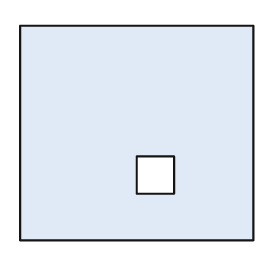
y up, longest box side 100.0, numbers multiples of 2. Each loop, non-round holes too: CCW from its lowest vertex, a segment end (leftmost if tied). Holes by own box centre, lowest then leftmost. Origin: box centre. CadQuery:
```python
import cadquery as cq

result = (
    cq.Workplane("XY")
    .moveTo(-50.0, -46.0)
    .lineTo(50.0, -46.0)
    .lineTo(50.0, 46.0)
    .lineTo(-50.0, 46.0)
    .close()
    .moveTo(0.0, -26.0)
    .lineTo(16.0, -26.0)
    .lineTo(16.0, -10.0)
    .lineTo(0.0, -10.0)
    .close()
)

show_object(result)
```